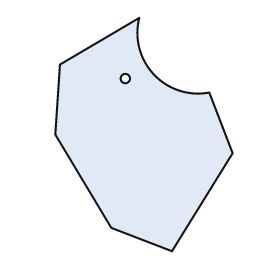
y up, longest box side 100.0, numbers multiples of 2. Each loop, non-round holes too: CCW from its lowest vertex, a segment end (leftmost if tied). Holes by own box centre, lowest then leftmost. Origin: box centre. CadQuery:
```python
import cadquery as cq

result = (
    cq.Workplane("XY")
    .moveTo(12.0, -50.0)
    .lineTo(38.0, -8.0)
    .lineTo(28.0, 18.0)
    .threePointArc((4.0, 26.0), (-2.0, 50.0))
    .lineTo(-36.0, 30.0)
    .lineTo(-38.0, 0.0)
    .lineTo(-14.0, -40.0)
    .close()
    .moveTo(-8.0, 24.0)
    .circle(2.0)
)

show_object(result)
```